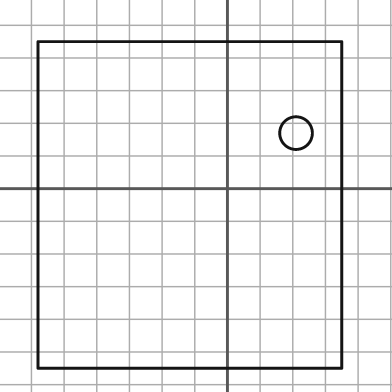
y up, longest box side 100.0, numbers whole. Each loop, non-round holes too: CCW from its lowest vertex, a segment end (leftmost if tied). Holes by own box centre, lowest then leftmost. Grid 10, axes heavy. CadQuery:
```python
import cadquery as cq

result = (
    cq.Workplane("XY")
    .moveTo(-58.0, -55.0)
    .lineTo(35.0, -55.0)
    .lineTo(35.0, 45.0)
    .lineTo(-58.0, 45.0)
    .close()
    .moveTo(21.0, 17.0)
    .circle(5.0)
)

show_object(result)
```